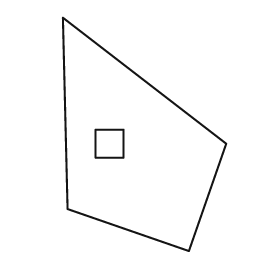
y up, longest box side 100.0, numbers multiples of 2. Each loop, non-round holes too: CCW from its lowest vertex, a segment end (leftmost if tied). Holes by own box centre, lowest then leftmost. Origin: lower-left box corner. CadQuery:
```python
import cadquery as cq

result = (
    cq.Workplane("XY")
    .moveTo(54.0, 0.0)
    .lineTo(70.0, 46.0)
    .lineTo(0.0, 100.0)
    .lineTo(2.0, 18.0)
    .close()
    .moveTo(14.0, 40.0)
    .lineTo(26.0, 40.0)
    .lineTo(26.0, 52.0)
    .lineTo(14.0, 52.0)
    .close()
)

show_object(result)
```